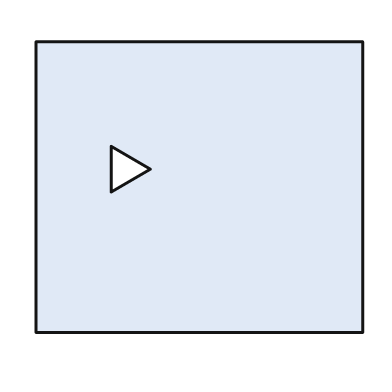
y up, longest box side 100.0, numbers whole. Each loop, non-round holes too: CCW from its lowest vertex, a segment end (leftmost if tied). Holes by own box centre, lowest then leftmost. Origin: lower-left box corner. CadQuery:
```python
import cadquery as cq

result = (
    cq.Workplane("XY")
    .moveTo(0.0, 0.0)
    .lineTo(100.0, 0.0)
    .lineTo(100.0, 89.0)
    .lineTo(0.0, 89.0)
    .close()
    .moveTo(23.0, 43.0)
    .lineTo(35.0, 50.0)
    .lineTo(23.0, 57.0)
    .close()
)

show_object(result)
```